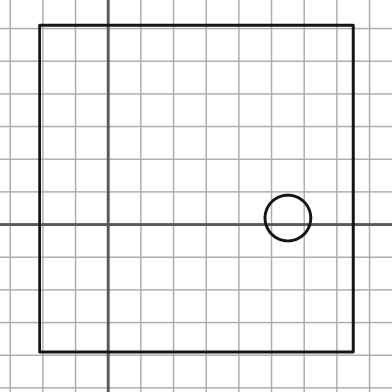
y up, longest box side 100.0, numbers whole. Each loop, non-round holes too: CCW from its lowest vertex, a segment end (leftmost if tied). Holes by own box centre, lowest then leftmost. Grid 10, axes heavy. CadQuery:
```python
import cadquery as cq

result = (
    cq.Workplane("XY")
    .moveTo(-21.0, -39.0)
    .lineTo(75.0, -39.0)
    .lineTo(75.0, 61.0)
    .lineTo(-21.0, 61.0)
    .close()
    .moveTo(55.0, 2.0)
    .circle(7.0)
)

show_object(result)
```